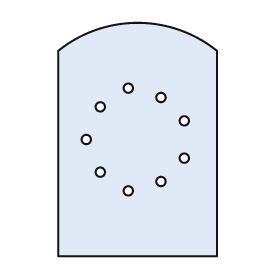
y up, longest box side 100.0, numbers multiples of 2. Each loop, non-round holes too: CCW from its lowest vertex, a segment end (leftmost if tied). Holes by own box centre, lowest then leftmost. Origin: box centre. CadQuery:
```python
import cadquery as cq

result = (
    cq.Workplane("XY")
    .moveTo(-34.0, -50.0)
    .lineTo(34.0, -50.0)
    .lineTo(34.0, 38.0)
    .threePointArc((0.0, 50.0), (-34.0, 38.0))
    .close()
    .moveTo(-4.0, -22.0)
    .circle(2.0)
    .moveTo(10.0, -18.0)
    .circle(2.0)
    .moveTo(-16.0, -14.0)
    .circle(2.0)
    .moveTo(20.0, -8.0)
    .circle(2.0)
    .moveTo(-22.0, 0.0)
    .circle(2.0)
    .moveTo(20.0, 8.0)
    .circle(2.0)
    .moveTo(-16.0, 14.0)
    .circle(2.0)
    .moveTo(10.0, 18.0)
    .circle(2.0)
    .moveTo(-4.0, 22.0)
    .circle(2.0)
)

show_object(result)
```